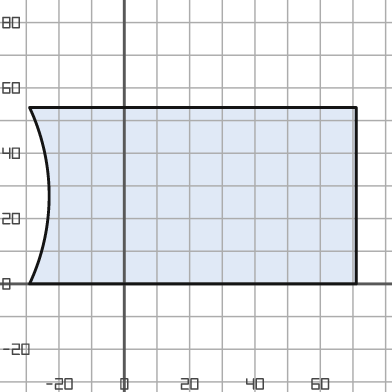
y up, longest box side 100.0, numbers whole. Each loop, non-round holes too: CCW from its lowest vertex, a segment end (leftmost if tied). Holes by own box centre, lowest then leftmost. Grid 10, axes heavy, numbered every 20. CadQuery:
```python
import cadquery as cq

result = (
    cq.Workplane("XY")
    .moveTo(-29.0, 0.0)
    .lineTo(71.0, 0.0)
    .lineTo(71.0, 54.0)
    .lineTo(-29.0, 54.0)
    .threePointArc((-23.0, 27.0), (-29.0, 0.0))
    .close()
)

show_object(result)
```